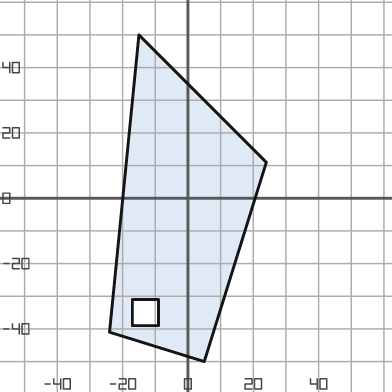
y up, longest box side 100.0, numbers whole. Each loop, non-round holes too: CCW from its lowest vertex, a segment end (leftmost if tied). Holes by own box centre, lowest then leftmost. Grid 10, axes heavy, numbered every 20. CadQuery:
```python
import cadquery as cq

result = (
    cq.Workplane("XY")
    .moveTo(5.0, -50.0)
    .lineTo(24.0, 11.0)
    .lineTo(-15.0, 50.0)
    .lineTo(-24.0, -41.0)
    .close()
    .moveTo(-17.0, -39.0)
    .lineTo(-9.0, -39.0)
    .lineTo(-9.0, -31.0)
    .lineTo(-17.0, -31.0)
    .close()
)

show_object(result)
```